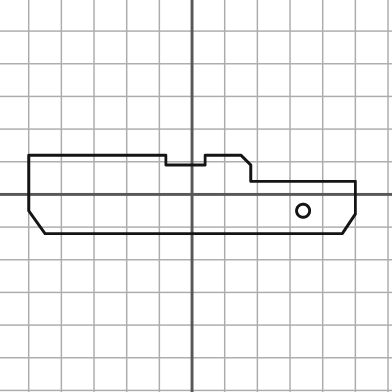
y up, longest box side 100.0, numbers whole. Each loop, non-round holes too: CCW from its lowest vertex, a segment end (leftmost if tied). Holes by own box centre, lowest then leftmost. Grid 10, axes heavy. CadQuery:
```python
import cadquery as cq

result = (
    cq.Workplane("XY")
    .moveTo(-45.0, -12.0)
    .lineTo(46.0, -12.0)
    .lineTo(50.0, -6.0)
    .lineTo(50.0, 4.0)
    .lineTo(18.0, 4.0)
    .lineTo(18.0, 9.0)
    .lineTo(15.0, 12.0)
    .lineTo(4.0, 12.0)
    .lineTo(4.0, 9.0)
    .lineTo(-8.0, 9.0)
    .lineTo(-8.0, 12.0)
    .lineTo(-50.0, 12.0)
    .lineTo(-50.0, -5.0)
    .close()
    .moveTo(34.0, -5.0)
    .circle(2.0)
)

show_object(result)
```